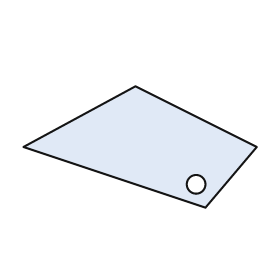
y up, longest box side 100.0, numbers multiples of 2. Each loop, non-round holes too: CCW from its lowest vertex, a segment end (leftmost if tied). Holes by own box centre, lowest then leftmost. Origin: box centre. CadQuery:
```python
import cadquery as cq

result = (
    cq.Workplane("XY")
    .moveTo(28.0, -26.0)
    .lineTo(50.0, 0.0)
    .lineTo(-2.0, 26.0)
    .lineTo(-50.0, 0.0)
    .close()
    .moveTo(24.0, -16.0)
    .circle(4.0)
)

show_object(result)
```